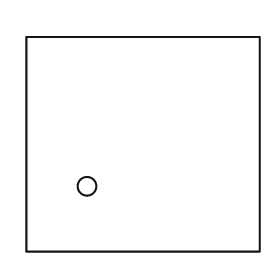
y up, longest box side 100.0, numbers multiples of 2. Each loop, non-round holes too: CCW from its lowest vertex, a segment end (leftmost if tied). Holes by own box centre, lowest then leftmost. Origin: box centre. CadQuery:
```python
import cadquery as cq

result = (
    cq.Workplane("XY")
    .moveTo(-50.0, -46.0)
    .lineTo(50.0, -46.0)
    .lineTo(50.0, 46.0)
    .lineTo(-50.0, 46.0)
    .close()
    .moveTo(-24.0, -18.0)
    .circle(4.0)
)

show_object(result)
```